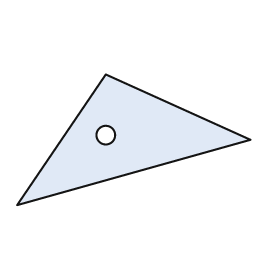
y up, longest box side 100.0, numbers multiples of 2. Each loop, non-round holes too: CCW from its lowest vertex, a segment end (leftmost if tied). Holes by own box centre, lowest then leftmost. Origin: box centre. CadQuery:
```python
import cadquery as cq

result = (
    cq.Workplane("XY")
    .moveTo(-50.0, -28.0)
    .lineTo(50.0, 0.0)
    .lineTo(-12.0, 28.0)
    .close()
    .moveTo(-12.0, 2.0)
    .circle(4.0)
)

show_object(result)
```